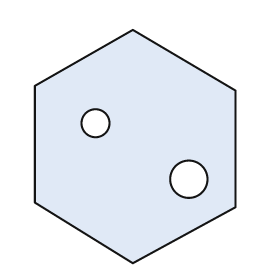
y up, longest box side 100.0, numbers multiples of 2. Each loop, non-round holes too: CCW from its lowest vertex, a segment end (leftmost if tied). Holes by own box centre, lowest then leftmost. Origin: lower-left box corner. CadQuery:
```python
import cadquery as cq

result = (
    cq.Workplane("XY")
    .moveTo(42.0, 0.0)
    .lineTo(86.0, 24.0)
    .lineTo(86.0, 74.0)
    .lineTo(42.0, 100.0)
    .lineTo(0.0, 76.0)
    .lineTo(0.0, 26.0)
    .close()
    .moveTo(66.0, 36.0)
    .circle(8.0)
    .moveTo(26.0, 60.0)
    .circle(6.0)
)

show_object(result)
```